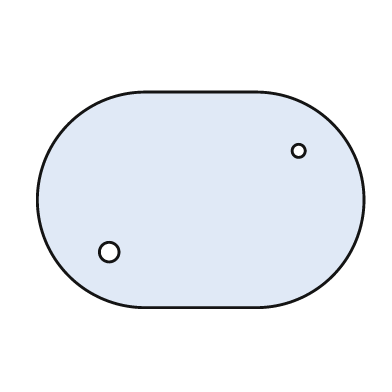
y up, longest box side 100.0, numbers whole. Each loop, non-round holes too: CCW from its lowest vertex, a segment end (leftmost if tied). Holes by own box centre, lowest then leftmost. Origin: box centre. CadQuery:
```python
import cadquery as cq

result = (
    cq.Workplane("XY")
    .moveTo(-17.0, -33.0)
    .lineTo(17.0, -33.0)
    .threePointArc((50.0, 0.0), (17.0, 33.0))
    .lineTo(-17.0, 33.0)
    .threePointArc((-50.0, 0.0), (-17.0, -33.0))
    .close()
    .moveTo(-28.0, -16.0)
    .circle(3.0)
    .moveTo(30.0, 15.0)
    .circle(2.0)
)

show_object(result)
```